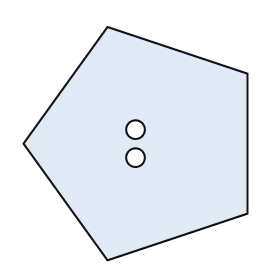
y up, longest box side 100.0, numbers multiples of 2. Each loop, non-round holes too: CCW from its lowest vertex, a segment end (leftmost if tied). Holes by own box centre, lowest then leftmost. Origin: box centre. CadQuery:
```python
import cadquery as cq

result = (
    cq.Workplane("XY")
    .moveTo(-12.0, -50.0)
    .lineTo(48.0, -30.0)
    .lineTo(48.0, 30.0)
    .lineTo(-12.0, 50.0)
    .lineTo(-48.0, 0.0)
    .close()
    .moveTo(0.0, -6.0)
    .circle(4.0)
    .moveTo(0.0, 6.0)
    .circle(4.0)
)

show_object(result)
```